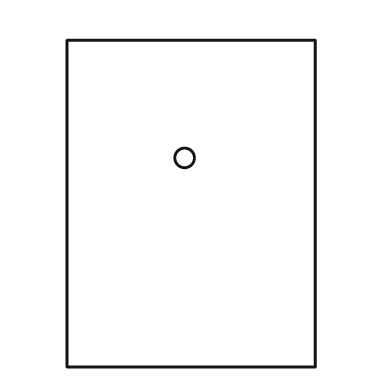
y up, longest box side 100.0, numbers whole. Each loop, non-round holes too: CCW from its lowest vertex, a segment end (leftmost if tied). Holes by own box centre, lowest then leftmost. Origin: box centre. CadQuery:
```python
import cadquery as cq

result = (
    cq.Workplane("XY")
    .moveTo(-38.0, -50.0)
    .lineTo(38.0, -50.0)
    .lineTo(38.0, 50.0)
    .lineTo(-38.0, 50.0)
    .close()
    .moveTo(-2.0, 14.0)
    .circle(3.0)
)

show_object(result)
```